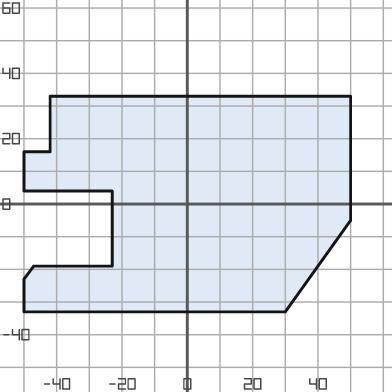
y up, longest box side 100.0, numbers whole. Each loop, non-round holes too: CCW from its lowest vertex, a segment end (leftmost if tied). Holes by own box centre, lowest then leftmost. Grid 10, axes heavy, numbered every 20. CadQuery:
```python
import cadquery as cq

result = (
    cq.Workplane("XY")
    .moveTo(-50.0, -33.0)
    .lineTo(30.0, -33.0)
    .lineTo(50.0, -5.0)
    .lineTo(50.0, 33.0)
    .lineTo(-42.0, 33.0)
    .lineTo(-42.0, 16.0)
    .lineTo(-50.0, 16.0)
    .lineTo(-50.0, 4.0)
    .lineTo(-23.0, 4.0)
    .lineTo(-23.0, -19.0)
    .lineTo(-47.0, -19.0)
    .lineTo(-50.0, -23.0)
    .close()
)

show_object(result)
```